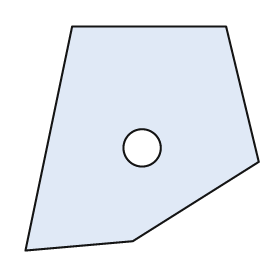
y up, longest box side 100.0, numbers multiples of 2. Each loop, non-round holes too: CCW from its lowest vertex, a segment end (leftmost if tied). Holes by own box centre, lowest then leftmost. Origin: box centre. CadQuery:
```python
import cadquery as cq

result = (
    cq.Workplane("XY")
    .moveTo(-50.0, -48.0)
    .lineTo(-4.0, -44.0)
    .lineTo(50.0, -10.0)
    .lineTo(36.0, 48.0)
    .lineTo(-30.0, 48.0)
    .close()
    .moveTo(0.0, -4.0)
    .circle(8.0)
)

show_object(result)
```